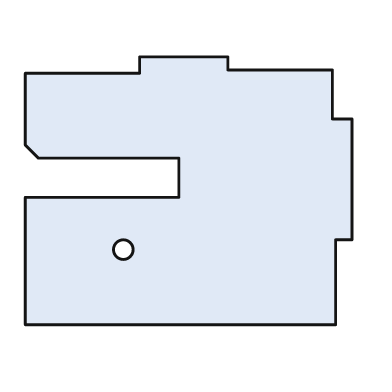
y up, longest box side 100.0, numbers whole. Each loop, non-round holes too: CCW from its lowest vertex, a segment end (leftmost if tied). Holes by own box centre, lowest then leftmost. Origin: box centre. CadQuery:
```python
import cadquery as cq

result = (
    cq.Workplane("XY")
    .moveTo(-50.0, -41.0)
    .lineTo(45.0, -41.0)
    .lineTo(45.0, -15.0)
    .lineTo(50.0, -15.0)
    .lineTo(50.0, 22.0)
    .lineTo(44.0, 22.0)
    .lineTo(44.0, 37.0)
    .lineTo(12.0, 37.0)
    .lineTo(12.0, 41.0)
    .lineTo(-15.0, 41.0)
    .lineTo(-15.0, 36.0)
    .lineTo(-50.0, 36.0)
    .lineTo(-50.0, 14.0)
    .lineTo(-46.0, 10.0)
    .lineTo(-3.0, 10.0)
    .lineTo(-3.0, -2.0)
    .lineTo(-50.0, -2.0)
    .close()
    .moveTo(-20.0, -18.0)
    .circle(3.0)
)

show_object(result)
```